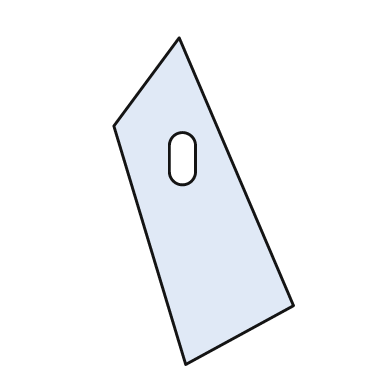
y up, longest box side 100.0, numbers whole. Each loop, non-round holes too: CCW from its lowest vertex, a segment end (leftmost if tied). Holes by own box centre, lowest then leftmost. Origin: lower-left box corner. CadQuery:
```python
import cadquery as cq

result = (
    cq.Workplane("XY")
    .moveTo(22.0, 0.0)
    .lineTo(55.0, 18.0)
    .lineTo(20.0, 100.0)
    .lineTo(0.0, 73.0)
    .close()
    .moveTo(17.0, 59.0)
    .threePointArc((21.0, 55.0), (25.0, 59.0))
    .lineTo(25.0, 67.0)
    .threePointArc((21.0, 71.0), (17.0, 67.0))
    .close()
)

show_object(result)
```